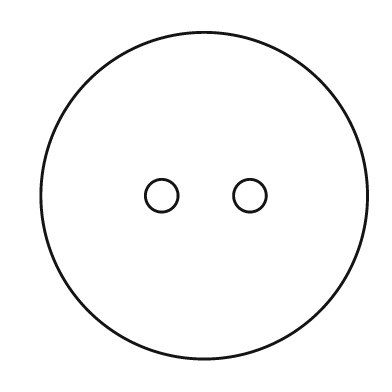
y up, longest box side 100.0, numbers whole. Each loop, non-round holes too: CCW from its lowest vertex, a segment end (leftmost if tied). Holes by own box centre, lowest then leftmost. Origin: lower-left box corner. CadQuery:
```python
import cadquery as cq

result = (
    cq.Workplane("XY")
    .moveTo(50.0, 50.0)
    .circle(50.0)
    .moveTo(37.0, 50.0)
    .circle(5.0)
    .moveTo(64.0, 50.0)
    .circle(5.0)
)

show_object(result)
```